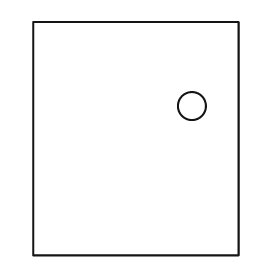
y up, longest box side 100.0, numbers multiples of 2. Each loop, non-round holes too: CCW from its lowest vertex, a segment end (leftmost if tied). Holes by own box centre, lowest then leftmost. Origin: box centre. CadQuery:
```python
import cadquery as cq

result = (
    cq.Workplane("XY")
    .moveTo(-44.0, -50.0)
    .lineTo(44.0, -50.0)
    .lineTo(44.0, 50.0)
    .lineTo(-44.0, 50.0)
    .close()
    .moveTo(24.0, 14.0)
    .circle(6.0)
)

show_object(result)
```